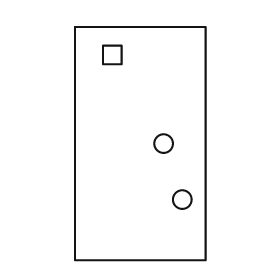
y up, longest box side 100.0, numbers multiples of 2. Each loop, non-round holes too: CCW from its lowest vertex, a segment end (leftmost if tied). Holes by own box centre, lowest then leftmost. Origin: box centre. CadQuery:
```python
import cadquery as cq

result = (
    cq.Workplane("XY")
    .moveTo(-28.0, -50.0)
    .lineTo(28.0, -50.0)
    .lineTo(28.0, 50.0)
    .lineTo(-28.0, 50.0)
    .close()
    .moveTo(18.0, -24.0)
    .circle(4.0)
    .moveTo(10.0, 0.0)
    .circle(4.0)
    .moveTo(-16.0, 34.0)
    .lineTo(-8.0, 34.0)
    .lineTo(-8.0, 42.0)
    .lineTo(-16.0, 42.0)
    .close()
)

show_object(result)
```